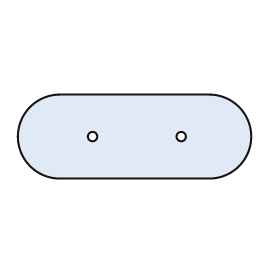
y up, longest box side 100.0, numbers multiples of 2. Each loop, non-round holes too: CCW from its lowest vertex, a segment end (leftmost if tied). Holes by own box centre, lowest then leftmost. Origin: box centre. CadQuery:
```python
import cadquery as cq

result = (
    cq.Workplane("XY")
    .moveTo(-32.0, -18.0)
    .lineTo(32.0, -18.0)
    .threePointArc((50.0, 0.0), (32.0, 18.0))
    .lineTo(-32.0, 18.0)
    .threePointArc((-50.0, 0.0), (-32.0, -18.0))
    .close()
    .moveTo(-18.0, 0.0)
    .circle(2.0)
    .moveTo(20.0, 0.0)
    .circle(2.0)
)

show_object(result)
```